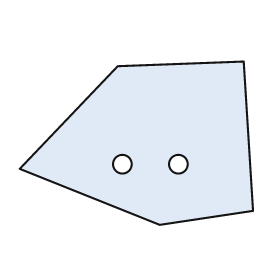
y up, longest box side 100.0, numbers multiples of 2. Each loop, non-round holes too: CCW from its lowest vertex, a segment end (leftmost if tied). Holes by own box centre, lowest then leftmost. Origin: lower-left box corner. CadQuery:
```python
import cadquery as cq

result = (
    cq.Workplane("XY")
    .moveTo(60.0, 0.0)
    .lineTo(100.0, 6.0)
    .lineTo(96.0, 70.0)
    .lineTo(42.0, 68.0)
    .lineTo(0.0, 24.0)
    .close()
    .moveTo(44.0, 26.0)
    .circle(4.0)
    .moveTo(68.0, 26.0)
    .circle(4.0)
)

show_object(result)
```